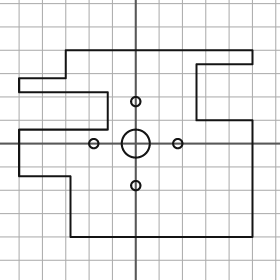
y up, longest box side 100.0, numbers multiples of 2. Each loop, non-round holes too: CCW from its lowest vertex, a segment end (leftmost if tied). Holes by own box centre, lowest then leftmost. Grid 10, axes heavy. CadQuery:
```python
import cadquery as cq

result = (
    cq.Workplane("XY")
    .moveTo(-28.0, -40.0)
    .lineTo(50.0, -40.0)
    .lineTo(50.0, 10.0)
    .lineTo(26.0, 10.0)
    .lineTo(26.0, 34.0)
    .lineTo(50.0, 34.0)
    .lineTo(50.0, 40.0)
    .lineTo(-30.0, 40.0)
    .lineTo(-30.0, 28.0)
    .lineTo(-50.0, 28.0)
    .lineTo(-50.0, 22.0)
    .lineTo(-12.0, 22.0)
    .lineTo(-12.0, 6.0)
    .lineTo(-50.0, 6.0)
    .lineTo(-50.0, -14.0)
    .lineTo(-28.0, -14.0)
    .close()
    .moveTo(0.0, -18.0)
    .circle(2.0)
    .moveTo(-18.0, 0.0)
    .circle(2.0)
    .moveTo(0.0, 0.0)
    .circle(6.0)
    .moveTo(18.0, 0.0)
    .circle(2.0)
    .moveTo(0.0, 18.0)
    .circle(2.0)
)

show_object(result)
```